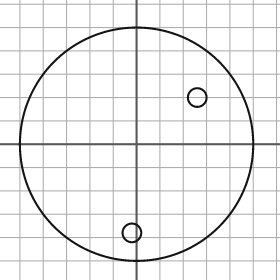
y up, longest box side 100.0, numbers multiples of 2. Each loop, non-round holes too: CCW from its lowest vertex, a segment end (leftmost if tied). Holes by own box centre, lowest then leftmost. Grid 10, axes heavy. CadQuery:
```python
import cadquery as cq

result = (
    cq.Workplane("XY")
    .moveTo(0.0, 0.0)
    .circle(50.0)
    .moveTo(-2.0, -38.0)
    .circle(4.0)
    .moveTo(26.0, 20.0)
    .circle(4.0)
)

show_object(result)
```